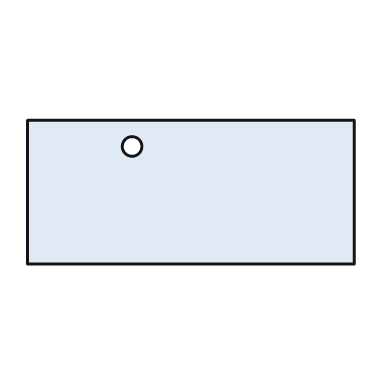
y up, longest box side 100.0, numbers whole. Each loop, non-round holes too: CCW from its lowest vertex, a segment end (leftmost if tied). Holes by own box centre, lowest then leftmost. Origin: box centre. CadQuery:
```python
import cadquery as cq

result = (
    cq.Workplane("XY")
    .moveTo(-50.0, -22.0)
    .lineTo(50.0, -22.0)
    .lineTo(50.0, 22.0)
    .lineTo(-50.0, 22.0)
    .close()
    .moveTo(-18.0, 14.0)
    .circle(3.0)
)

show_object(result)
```